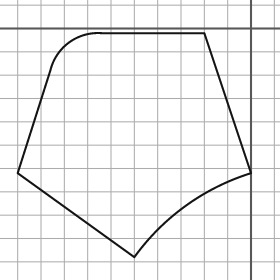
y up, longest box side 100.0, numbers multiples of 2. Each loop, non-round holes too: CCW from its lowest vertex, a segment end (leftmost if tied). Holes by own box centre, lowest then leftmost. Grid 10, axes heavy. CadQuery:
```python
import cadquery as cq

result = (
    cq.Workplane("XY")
    .moveTo(-50.0, -98.0)
    .threePointArc((-28.0, -76.0), (0.0, -62.0))
    .lineTo(-20.0, -2.0)
    .lineTo(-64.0, -2.0)
    .threePointArc((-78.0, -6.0), (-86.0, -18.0))
    .lineTo(-100.0, -62.0)
    .close()
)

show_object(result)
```